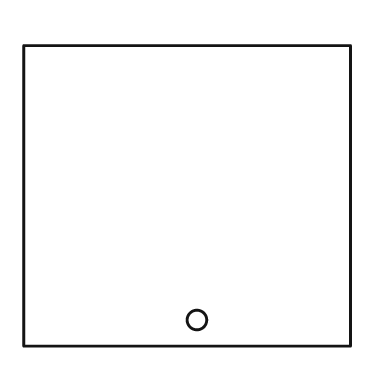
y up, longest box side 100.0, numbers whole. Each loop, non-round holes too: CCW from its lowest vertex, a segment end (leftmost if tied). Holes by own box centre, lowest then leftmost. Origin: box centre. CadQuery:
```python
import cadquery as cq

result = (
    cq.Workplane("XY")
    .moveTo(-50.0, -46.0)
    .lineTo(50.0, -46.0)
    .lineTo(50.0, 46.0)
    .lineTo(-50.0, 46.0)
    .close()
    .moveTo(3.0, -38.0)
    .circle(3.0)
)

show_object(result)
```